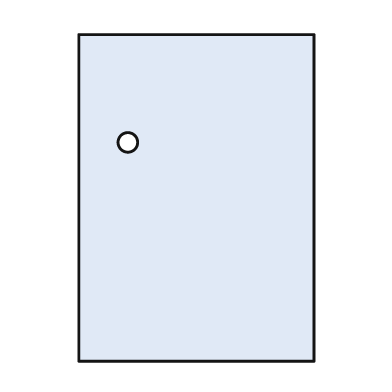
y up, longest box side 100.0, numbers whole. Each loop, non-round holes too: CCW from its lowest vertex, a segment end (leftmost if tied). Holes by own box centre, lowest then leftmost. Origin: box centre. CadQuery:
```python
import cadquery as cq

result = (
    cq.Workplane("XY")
    .moveTo(-36.0, -50.0)
    .lineTo(36.0, -50.0)
    .lineTo(36.0, 50.0)
    .lineTo(-36.0, 50.0)
    .close()
    .moveTo(-21.0, 17.0)
    .circle(3.0)
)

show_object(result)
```